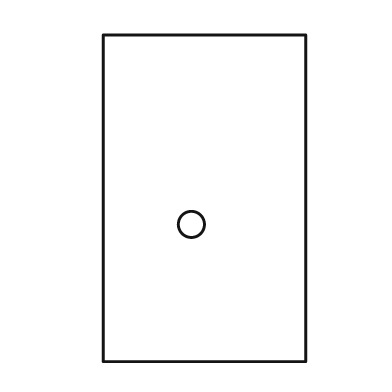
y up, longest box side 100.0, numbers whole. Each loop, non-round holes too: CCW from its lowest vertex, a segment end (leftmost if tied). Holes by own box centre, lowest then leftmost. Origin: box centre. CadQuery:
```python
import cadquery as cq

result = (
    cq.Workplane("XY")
    .moveTo(-31.0, -50.0)
    .lineTo(31.0, -50.0)
    .lineTo(31.0, 50.0)
    .lineTo(-31.0, 50.0)
    .close()
    .moveTo(-4.0, -8.0)
    .circle(4.0)
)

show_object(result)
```